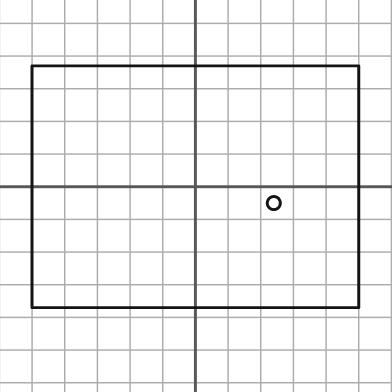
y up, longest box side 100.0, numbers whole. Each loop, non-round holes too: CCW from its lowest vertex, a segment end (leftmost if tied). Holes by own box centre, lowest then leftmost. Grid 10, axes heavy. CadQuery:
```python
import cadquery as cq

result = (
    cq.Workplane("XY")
    .moveTo(-50.0, -37.0)
    .lineTo(50.0, -37.0)
    .lineTo(50.0, 37.0)
    .lineTo(-50.0, 37.0)
    .close()
    .moveTo(24.0, -5.0)
    .circle(2.0)
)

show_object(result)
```